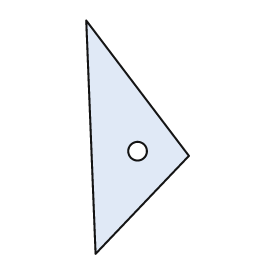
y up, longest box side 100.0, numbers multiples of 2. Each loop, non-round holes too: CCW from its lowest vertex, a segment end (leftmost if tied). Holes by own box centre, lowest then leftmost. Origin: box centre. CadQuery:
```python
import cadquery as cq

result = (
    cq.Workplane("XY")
    .moveTo(-18.0, -50.0)
    .lineTo(22.0, -8.0)
    .lineTo(-22.0, 50.0)
    .close()
    .moveTo(0.0, -6.0)
    .circle(4.0)
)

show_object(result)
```